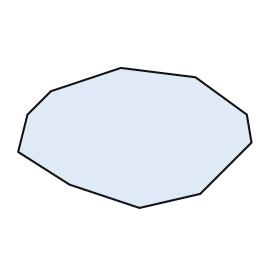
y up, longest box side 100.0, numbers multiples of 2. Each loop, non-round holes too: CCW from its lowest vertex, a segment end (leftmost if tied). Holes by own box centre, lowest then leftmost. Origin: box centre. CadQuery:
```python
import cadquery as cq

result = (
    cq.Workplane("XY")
    .moveTo(2.0, -30.0)
    .lineTo(28.0, -24.0)
    .lineTo(50.0, -2.0)
    .lineTo(48.0, 10.0)
    .lineTo(26.0, 26.0)
    .lineTo(-6.0, 30.0)
    .lineTo(-36.0, 20.0)
    .lineTo(-46.0, 10.0)
    .lineTo(-50.0, -6.0)
    .lineTo(-28.0, -20.0)
    .close()
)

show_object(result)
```